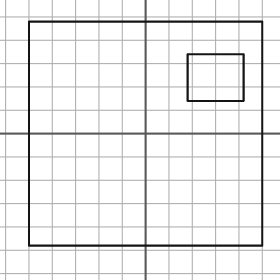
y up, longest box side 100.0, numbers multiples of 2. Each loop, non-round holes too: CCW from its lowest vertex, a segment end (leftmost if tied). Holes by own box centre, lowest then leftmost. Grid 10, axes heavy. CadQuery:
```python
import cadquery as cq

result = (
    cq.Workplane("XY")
    .moveTo(-50.0, -48.0)
    .lineTo(50.0, -48.0)
    .lineTo(50.0, 48.0)
    .lineTo(-50.0, 48.0)
    .close()
    .moveTo(18.0, 14.0)
    .lineTo(42.0, 14.0)
    .lineTo(42.0, 34.0)
    .lineTo(18.0, 34.0)
    .close()
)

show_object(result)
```